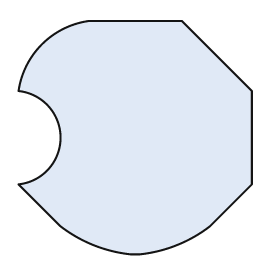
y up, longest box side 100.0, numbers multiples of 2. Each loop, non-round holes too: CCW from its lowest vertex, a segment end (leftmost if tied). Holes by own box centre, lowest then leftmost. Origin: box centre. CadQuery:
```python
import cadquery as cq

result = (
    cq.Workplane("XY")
    .moveTo(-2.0, -50.0)
    .lineTo(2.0, -50.0)
    .threePointArc((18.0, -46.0), (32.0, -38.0))
    .lineTo(50.0, -20.0)
    .lineTo(50.0, 20.0)
    .lineTo(20.0, 50.0)
    .lineTo(-20.0, 50.0)
    .threePointArc((-40.0, 40.0), (-50.0, 20.0))
    .threePointArc((-32.0, 0.0), (-50.0, -20.0))
    .lineTo(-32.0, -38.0)
    .threePointArc((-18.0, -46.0), (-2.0, -50.0))
    .close()
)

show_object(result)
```